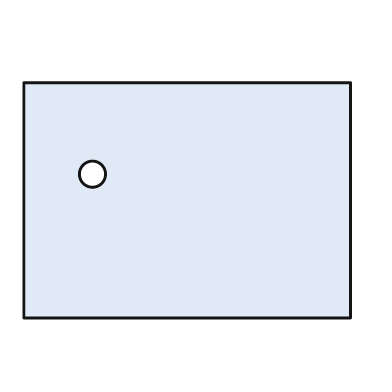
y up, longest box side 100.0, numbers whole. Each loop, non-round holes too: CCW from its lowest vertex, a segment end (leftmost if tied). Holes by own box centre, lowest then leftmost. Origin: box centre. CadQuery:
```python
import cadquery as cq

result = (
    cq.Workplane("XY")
    .moveTo(-50.0, -36.0)
    .lineTo(50.0, -36.0)
    .lineTo(50.0, 36.0)
    .lineTo(-50.0, 36.0)
    .close()
    .moveTo(-29.0, 8.0)
    .circle(4.0)
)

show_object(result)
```